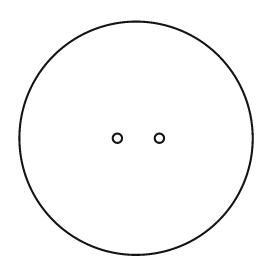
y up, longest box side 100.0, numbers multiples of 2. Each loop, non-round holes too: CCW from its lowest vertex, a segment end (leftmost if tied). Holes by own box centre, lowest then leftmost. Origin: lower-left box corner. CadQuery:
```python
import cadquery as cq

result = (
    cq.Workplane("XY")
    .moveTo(50.0, 50.0)
    .circle(50.0)
    .moveTo(42.0, 50.0)
    .circle(2.0)
    .moveTo(60.0, 50.0)
    .circle(2.0)
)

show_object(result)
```